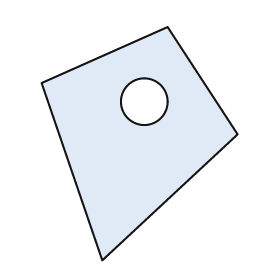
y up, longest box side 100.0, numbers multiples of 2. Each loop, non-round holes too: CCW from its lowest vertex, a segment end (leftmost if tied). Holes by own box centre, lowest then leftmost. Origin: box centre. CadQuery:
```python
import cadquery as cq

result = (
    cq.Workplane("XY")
    .moveTo(-16.0, -50.0)
    .lineTo(42.0, 4.0)
    .lineTo(12.0, 50.0)
    .lineTo(-42.0, 26.0)
    .close()
    .moveTo(2.0, 18.0)
    .circle(10.0)
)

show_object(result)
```